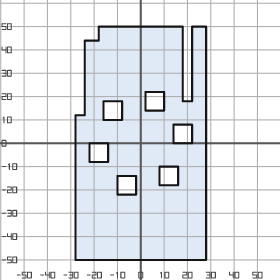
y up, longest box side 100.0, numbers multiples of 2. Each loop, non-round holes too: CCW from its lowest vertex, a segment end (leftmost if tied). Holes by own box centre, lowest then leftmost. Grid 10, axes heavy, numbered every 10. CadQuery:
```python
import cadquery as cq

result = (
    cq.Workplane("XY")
    .moveTo(-28.0, -50.0)
    .lineTo(28.0, -50.0)
    .lineTo(28.0, 50.0)
    .lineTo(22.0, 50.0)
    .lineTo(22.0, 18.0)
    .lineTo(18.0, 18.0)
    .lineTo(18.0, 50.0)
    .lineTo(-18.0, 50.0)
    .lineTo(-18.0, 44.0)
    .lineTo(-24.0, 44.0)
    .lineTo(-24.0, 12.0)
    .lineTo(-28.0, 12.0)
    .close()
    .moveTo(-10.0, -22.0)
    .lineTo(-2.0, -22.0)
    .lineTo(-2.0, -14.0)
    .lineTo(-10.0, -14.0)
    .close()
    .moveTo(8.0, -18.0)
    .lineTo(16.0, -18.0)
    .lineTo(16.0, -10.0)
    .lineTo(8.0, -10.0)
    .close()
    .moveTo(-22.0, -8.0)
    .lineTo(-14.0, -8.0)
    .lineTo(-14.0, 0.0)
    .lineTo(-22.0, 0.0)
    .close()
    .moveTo(14.0, 0.0)
    .lineTo(22.0, 0.0)
    .lineTo(22.0, 8.0)
    .lineTo(14.0, 8.0)
    .close()
    .moveTo(-16.0, 10.0)
    .lineTo(-8.0, 10.0)
    .lineTo(-8.0, 18.0)
    .lineTo(-16.0, 18.0)
    .close()
    .moveTo(2.0, 14.0)
    .lineTo(10.0, 14.0)
    .lineTo(10.0, 22.0)
    .lineTo(2.0, 22.0)
    .close()
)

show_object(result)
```